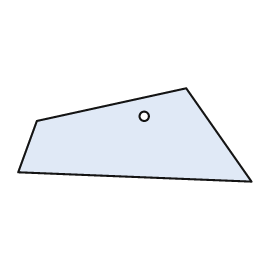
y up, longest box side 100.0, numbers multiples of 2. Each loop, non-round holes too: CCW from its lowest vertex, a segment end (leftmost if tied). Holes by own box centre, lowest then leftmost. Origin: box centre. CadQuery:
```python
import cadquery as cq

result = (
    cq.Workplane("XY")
    .moveTo(50.0, -20.0)
    .lineTo(22.0, 20.0)
    .lineTo(-42.0, 6.0)
    .lineTo(-50.0, -16.0)
    .close()
    .moveTo(4.0, 8.0)
    .circle(2.0)
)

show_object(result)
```